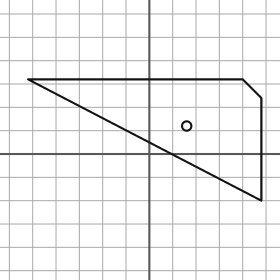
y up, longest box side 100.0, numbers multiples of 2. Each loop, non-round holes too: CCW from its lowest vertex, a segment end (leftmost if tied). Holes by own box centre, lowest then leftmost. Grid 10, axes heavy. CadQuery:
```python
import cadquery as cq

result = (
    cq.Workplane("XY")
    .moveTo(48.0, -20.0)
    .lineTo(48.0, 24.0)
    .lineTo(40.0, 32.0)
    .lineTo(-52.0, 32.0)
    .close()
    .moveTo(16.0, 12.0)
    .circle(2.0)
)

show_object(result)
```